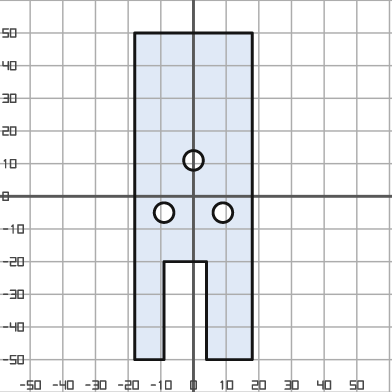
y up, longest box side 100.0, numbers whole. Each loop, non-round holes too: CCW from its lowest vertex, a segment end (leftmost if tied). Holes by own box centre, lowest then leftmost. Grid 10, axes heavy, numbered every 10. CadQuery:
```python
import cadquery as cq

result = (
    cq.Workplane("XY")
    .moveTo(-18.0, -50.0)
    .lineTo(-9.0, -50.0)
    .lineTo(-9.0, -20.0)
    .lineTo(4.0, -20.0)
    .lineTo(4.0, -50.0)
    .lineTo(18.0, -50.0)
    .lineTo(18.0, 50.0)
    .lineTo(-18.0, 50.0)
    .close()
    .moveTo(-9.0, -5.0)
    .circle(3.0)
    .moveTo(9.0, -5.0)
    .circle(3.0)
    .moveTo(0.0, 11.0)
    .circle(3.0)
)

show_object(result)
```